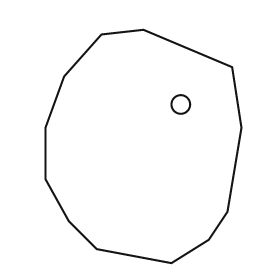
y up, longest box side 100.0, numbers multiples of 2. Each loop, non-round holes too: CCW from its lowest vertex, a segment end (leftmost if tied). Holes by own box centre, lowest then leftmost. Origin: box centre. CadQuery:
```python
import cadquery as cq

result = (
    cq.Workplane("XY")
    .moveTo(12.0, -50.0)
    .lineTo(28.0, -40.0)
    .lineTo(36.0, -28.0)
    .lineTo(42.0, 8.0)
    .lineTo(38.0, 34.0)
    .lineTo(0.0, 50.0)
    .lineTo(-18.0, 48.0)
    .lineTo(-34.0, 30.0)
    .lineTo(-42.0, 8.0)
    .lineTo(-42.0, -14.0)
    .lineTo(-32.0, -32.0)
    .lineTo(-20.0, -44.0)
    .close()
    .moveTo(16.0, 18.0)
    .circle(4.0)
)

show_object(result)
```